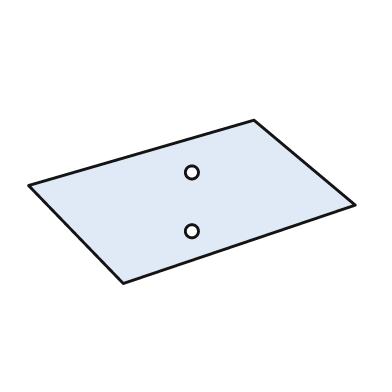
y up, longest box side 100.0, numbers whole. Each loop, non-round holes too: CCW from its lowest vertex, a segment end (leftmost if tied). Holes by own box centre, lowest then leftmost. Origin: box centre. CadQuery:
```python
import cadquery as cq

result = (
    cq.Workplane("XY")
    .moveTo(-21.0, -25.0)
    .lineTo(50.0, -1.0)
    .lineTo(19.0, 25.0)
    .lineTo(-50.0, 5.0)
    .close()
    .moveTo(0.0, -9.0)
    .circle(2.0)
    .moveTo(0.0, 9.0)
    .circle(2.0)
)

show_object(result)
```